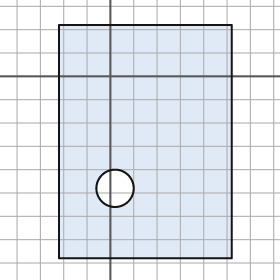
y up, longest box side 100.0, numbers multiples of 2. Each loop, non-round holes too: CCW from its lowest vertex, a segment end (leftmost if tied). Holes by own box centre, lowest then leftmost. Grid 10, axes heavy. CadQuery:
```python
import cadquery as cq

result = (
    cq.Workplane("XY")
    .moveTo(-22.0, -78.0)
    .lineTo(52.0, -78.0)
    .lineTo(52.0, 22.0)
    .lineTo(-22.0, 22.0)
    .close()
    .moveTo(2.0, -48.0)
    .circle(8.0)
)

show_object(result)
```